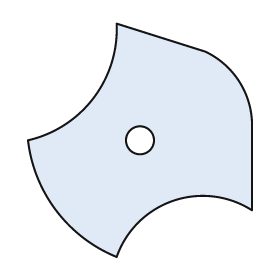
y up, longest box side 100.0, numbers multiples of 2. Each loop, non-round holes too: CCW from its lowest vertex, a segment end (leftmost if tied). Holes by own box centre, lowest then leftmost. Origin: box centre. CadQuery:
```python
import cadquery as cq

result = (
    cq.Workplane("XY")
    .moveTo(-10.0, -50.0)
    .threePointArc((14.0, -26.0), (48.0, -30.0))
    .lineTo(48.0, 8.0)
    .threePointArc((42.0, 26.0), (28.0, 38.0))
    .lineTo(-10.0, 50.0)
    .threePointArc((-20.0, 18.0), (-48.0, 0.0))
    .threePointArc((-36.0, -30.0), (-10.0, -50.0))
    .close()
    .moveTo(0.0, 0.0)
    .circle(6.0)
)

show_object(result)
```